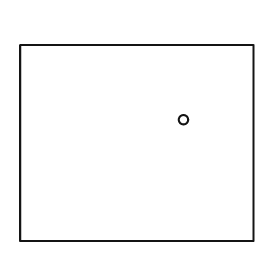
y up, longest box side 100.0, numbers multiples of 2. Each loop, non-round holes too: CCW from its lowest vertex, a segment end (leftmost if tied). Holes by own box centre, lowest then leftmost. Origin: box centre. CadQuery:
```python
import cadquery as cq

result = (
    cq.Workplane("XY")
    .moveTo(-50.0, -42.0)
    .lineTo(50.0, -42.0)
    .lineTo(50.0, 42.0)
    .lineTo(-50.0, 42.0)
    .close()
    .moveTo(20.0, 10.0)
    .circle(2.0)
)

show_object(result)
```